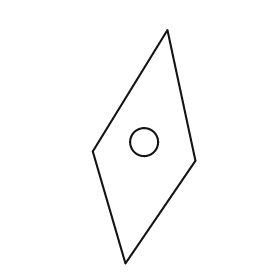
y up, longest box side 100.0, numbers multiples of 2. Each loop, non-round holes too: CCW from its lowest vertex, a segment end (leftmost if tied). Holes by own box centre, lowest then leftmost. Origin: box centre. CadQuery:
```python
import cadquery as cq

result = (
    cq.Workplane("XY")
    .moveTo(-8.0, -50.0)
    .lineTo(22.0, -6.0)
    .lineTo(10.0, 50.0)
    .lineTo(-22.0, -2.0)
    .close()
    .moveTo(0.0, 2.0)
    .circle(6.0)
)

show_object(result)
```